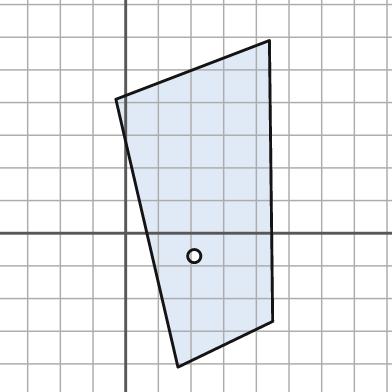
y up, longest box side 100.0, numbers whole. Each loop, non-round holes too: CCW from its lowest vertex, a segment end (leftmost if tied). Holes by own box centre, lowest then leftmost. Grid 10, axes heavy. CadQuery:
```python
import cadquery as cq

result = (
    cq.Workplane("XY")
    .moveTo(16.0, -41.0)
    .lineTo(45.0, -27.0)
    .lineTo(44.0, 59.0)
    .lineTo(-3.0, 41.0)
    .close()
    .moveTo(21.0, -7.0)
    .circle(2.0)
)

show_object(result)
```